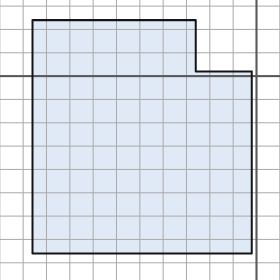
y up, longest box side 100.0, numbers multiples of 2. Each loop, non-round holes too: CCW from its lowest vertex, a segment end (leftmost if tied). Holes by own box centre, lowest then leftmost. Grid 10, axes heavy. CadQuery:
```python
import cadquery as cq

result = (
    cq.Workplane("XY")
    .moveTo(-96.0, -76.0)
    .lineTo(-2.0, -76.0)
    .lineTo(-2.0, 2.0)
    .lineTo(-26.0, 2.0)
    .lineTo(-26.0, 24.0)
    .lineTo(-96.0, 24.0)
    .close()
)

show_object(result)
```